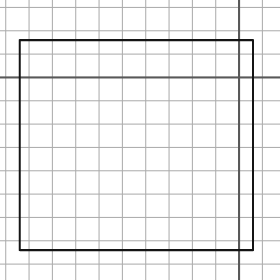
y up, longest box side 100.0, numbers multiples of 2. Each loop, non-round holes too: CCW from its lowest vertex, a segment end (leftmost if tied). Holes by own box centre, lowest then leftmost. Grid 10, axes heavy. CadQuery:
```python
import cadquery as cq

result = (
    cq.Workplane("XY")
    .moveTo(-94.0, -74.0)
    .lineTo(6.0, -74.0)
    .lineTo(6.0, 16.0)
    .lineTo(-94.0, 16.0)
    .close()
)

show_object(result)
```